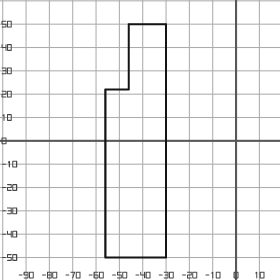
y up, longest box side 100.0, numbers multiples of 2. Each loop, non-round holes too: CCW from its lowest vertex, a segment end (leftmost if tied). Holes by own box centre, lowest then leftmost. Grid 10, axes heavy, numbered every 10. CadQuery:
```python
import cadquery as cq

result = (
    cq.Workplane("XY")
    .moveTo(-56.0, -50.0)
    .lineTo(-30.0, -50.0)
    .lineTo(-30.0, 50.0)
    .lineTo(-46.0, 50.0)
    .lineTo(-46.0, 22.0)
    .lineTo(-56.0, 22.0)
    .close()
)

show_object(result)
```